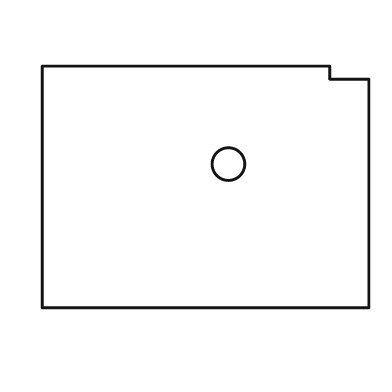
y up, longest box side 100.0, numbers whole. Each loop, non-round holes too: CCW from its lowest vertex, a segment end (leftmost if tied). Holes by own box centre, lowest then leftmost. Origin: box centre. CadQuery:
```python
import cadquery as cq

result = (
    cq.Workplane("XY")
    .moveTo(-50.0, -37.0)
    .lineTo(50.0, -37.0)
    .lineTo(50.0, 33.0)
    .lineTo(38.0, 33.0)
    .lineTo(38.0, 37.0)
    .lineTo(-50.0, 37.0)
    .close()
    .moveTo(7.0, 7.0)
    .circle(5.0)
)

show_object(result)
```